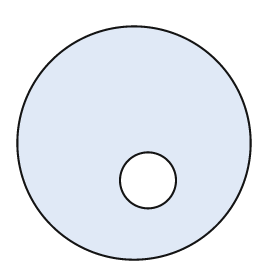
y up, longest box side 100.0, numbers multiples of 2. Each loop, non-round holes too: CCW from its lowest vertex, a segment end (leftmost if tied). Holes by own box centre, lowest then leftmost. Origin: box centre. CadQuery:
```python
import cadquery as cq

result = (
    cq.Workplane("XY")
    .moveTo(0.0, 0.0)
    .circle(50.0)
    .moveTo(6.0, -16.0)
    .circle(12.0)
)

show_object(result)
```